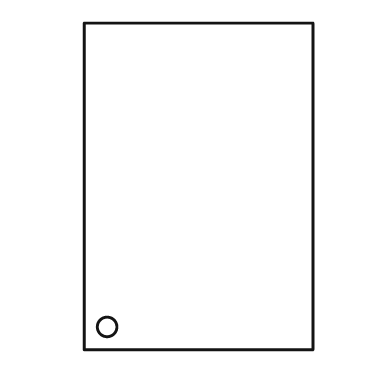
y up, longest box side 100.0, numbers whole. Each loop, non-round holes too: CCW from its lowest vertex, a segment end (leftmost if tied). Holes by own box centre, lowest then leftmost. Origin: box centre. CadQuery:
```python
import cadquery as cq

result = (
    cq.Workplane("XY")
    .moveTo(-35.0, -50.0)
    .lineTo(35.0, -50.0)
    .lineTo(35.0, 50.0)
    .lineTo(-35.0, 50.0)
    .close()
    .moveTo(-28.0, -43.0)
    .circle(3.0)
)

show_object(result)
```